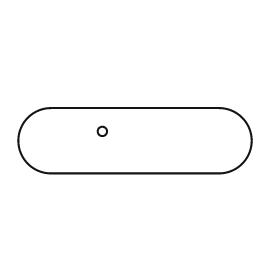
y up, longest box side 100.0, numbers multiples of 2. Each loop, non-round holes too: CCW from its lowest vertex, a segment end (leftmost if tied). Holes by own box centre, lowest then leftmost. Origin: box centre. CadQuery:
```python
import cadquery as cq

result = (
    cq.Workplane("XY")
    .moveTo(-36.0, -14.0)
    .lineTo(36.0, -14.0)
    .threePointArc((50.0, 0.0), (36.0, 14.0))
    .lineTo(-36.0, 14.0)
    .threePointArc((-50.0, 0.0), (-36.0, -14.0))
    .close()
    .moveTo(-14.0, 4.0)
    .circle(2.0)
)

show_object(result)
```